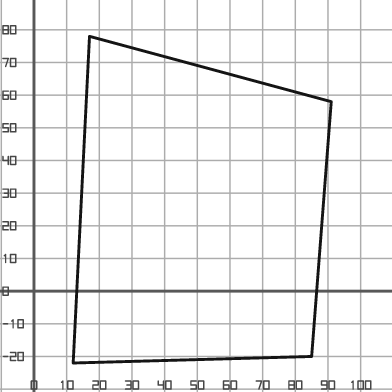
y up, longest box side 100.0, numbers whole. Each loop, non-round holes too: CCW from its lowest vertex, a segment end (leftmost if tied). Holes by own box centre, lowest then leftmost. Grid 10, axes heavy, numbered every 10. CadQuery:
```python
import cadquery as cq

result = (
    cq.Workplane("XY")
    .moveTo(12.0, -22.0)
    .lineTo(85.0, -20.0)
    .lineTo(91.0, 58.0)
    .lineTo(17.0, 78.0)
    .close()
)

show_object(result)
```